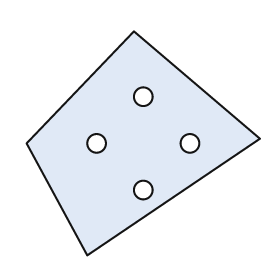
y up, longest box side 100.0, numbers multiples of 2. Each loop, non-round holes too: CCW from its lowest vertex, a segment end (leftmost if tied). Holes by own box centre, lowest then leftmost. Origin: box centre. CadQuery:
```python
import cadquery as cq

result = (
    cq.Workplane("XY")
    .moveTo(-24.0, -48.0)
    .lineTo(50.0, 2.0)
    .lineTo(-4.0, 48.0)
    .lineTo(-50.0, 0.0)
    .close()
    .moveTo(0.0, -20.0)
    .circle(4.0)
    .moveTo(-20.0, 0.0)
    .circle(4.0)
    .moveTo(20.0, 0.0)
    .circle(4.0)
    .moveTo(0.0, 20.0)
    .circle(4.0)
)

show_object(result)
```